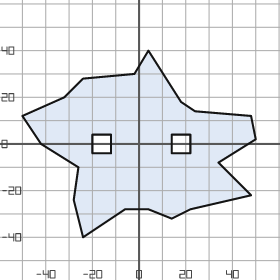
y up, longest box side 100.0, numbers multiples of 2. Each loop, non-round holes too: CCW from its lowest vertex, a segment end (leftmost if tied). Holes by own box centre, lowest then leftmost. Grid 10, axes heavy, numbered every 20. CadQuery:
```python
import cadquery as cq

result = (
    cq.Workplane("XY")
    .moveTo(-24.0, -40.0)
    .lineTo(-6.0, -28.0)
    .lineTo(4.0, -28.0)
    .lineTo(14.0, -32.0)
    .lineTo(22.0, -28.0)
    .lineTo(48.0, -22.0)
    .lineTo(34.0, -8.0)
    .lineTo(50.0, 2.0)
    .lineTo(48.0, 12.0)
    .lineTo(24.0, 14.0)
    .lineTo(18.0, 18.0)
    .lineTo(4.0, 40.0)
    .lineTo(-2.0, 30.0)
    .lineTo(-24.0, 28.0)
    .lineTo(-32.0, 20.0)
    .lineTo(-50.0, 12.0)
    .lineTo(-42.0, 0.0)
    .lineTo(-26.0, -10.0)
    .lineTo(-28.0, -24.0)
    .close()
    .moveTo(-20.0, -4.0)
    .lineTo(-12.0, -4.0)
    .lineTo(-12.0, 4.0)
    .lineTo(-20.0, 4.0)
    .close()
    .moveTo(14.0, -4.0)
    .lineTo(22.0, -4.0)
    .lineTo(22.0, 4.0)
    .lineTo(14.0, 4.0)
    .close()
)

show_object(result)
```